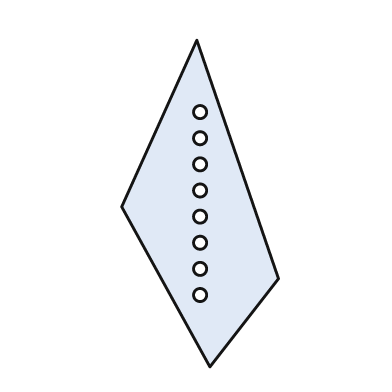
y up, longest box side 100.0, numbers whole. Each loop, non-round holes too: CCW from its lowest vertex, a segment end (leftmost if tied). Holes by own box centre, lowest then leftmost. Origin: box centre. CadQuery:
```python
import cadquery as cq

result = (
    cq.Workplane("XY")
    .moveTo(3.0, -50.0)
    .lineTo(24.0, -23.0)
    .lineTo(-1.0, 50.0)
    .lineTo(-24.0, -1.0)
    .close()
    .moveTo(0.0, -28.0)
    .circle(2.0)
    .moveTo(0.0, -20.0)
    .circle(2.0)
    .moveTo(0.0, -12.0)
    .circle(2.0)
    .moveTo(0.0, -4.0)
    .circle(2.0)
    .moveTo(0.0, 4.0)
    .circle(2.0)
    .moveTo(0.0, 12.0)
    .circle(2.0)
    .moveTo(0.0, 20.0)
    .circle(2.0)
    .moveTo(0.0, 28.0)
    .circle(2.0)
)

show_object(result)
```